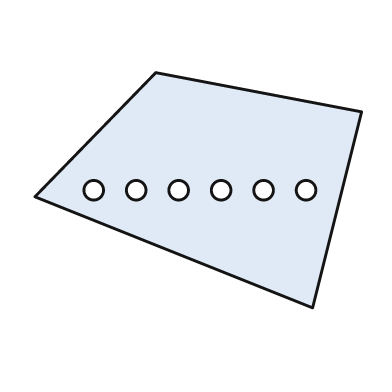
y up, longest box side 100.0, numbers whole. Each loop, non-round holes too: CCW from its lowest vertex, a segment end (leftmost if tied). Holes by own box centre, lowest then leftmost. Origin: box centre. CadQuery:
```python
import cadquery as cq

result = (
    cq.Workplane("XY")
    .moveTo(35.0, -36.0)
    .lineTo(50.0, 24.0)
    .lineTo(-13.0, 36.0)
    .lineTo(-50.0, -2.0)
    .close()
    .moveTo(-32.0, 0.0)
    .circle(3.0)
    .moveTo(-19.0, 0.0)
    .circle(3.0)
    .moveTo(-6.0, 0.0)
    .circle(3.0)
    .moveTo(7.0, 0.0)
    .circle(3.0)
    .moveTo(20.0, 0.0)
    .circle(3.0)
    .moveTo(33.0, 0.0)
    .circle(3.0)
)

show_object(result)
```